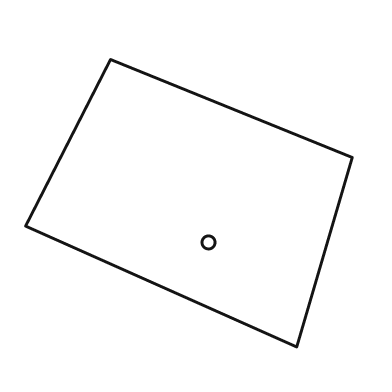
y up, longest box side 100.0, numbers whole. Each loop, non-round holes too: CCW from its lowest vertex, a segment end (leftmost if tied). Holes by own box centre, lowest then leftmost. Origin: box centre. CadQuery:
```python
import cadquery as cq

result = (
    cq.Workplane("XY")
    .moveTo(33.0, -44.0)
    .lineTo(50.0, 14.0)
    .lineTo(-24.0, 44.0)
    .lineTo(-50.0, -7.0)
    .close()
    .moveTo(6.0, -12.0)
    .circle(2.0)
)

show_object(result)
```